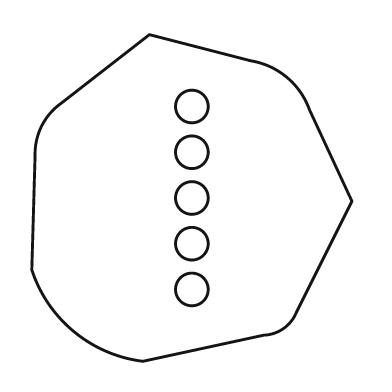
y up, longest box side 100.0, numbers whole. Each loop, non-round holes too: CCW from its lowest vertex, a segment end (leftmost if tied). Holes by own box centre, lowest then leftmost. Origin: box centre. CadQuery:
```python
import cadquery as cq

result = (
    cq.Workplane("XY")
    .moveTo(-15.0, -50.0)
    .lineTo(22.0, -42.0)
    .threePointArc((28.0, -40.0), (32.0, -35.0))
    .lineTo(49.0, -1.0)
    .lineTo(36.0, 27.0)
    .threePointArc((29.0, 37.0), (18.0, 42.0))
    .lineTo(-13.0, 50.0)
    .lineTo(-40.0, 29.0)
    .threePointArc((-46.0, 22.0), (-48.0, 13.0))
    .lineTo(-49.0, -22.0)
    .threePointArc((-36.0, -41.0), (-15.0, -50.0))
    .close()
    .moveTo(0.0, -28.0)
    .circle(5.0)
    .moveTo(0.0, -14.0)
    .circle(5.0)
    .moveTo(0.0, 0.0)
    .circle(5.0)
    .moveTo(0.0, 14.0)
    .circle(5.0)
    .moveTo(0.0, 28.0)
    .circle(5.0)
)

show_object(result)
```